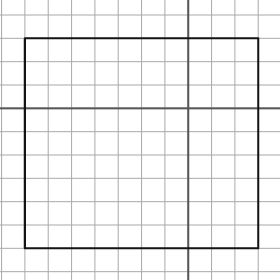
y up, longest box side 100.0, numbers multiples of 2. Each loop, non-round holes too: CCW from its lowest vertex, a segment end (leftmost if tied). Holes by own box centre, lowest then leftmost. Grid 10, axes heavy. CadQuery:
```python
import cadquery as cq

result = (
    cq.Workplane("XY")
    .moveTo(-70.0, -60.0)
    .lineTo(30.0, -60.0)
    .lineTo(30.0, 30.0)
    .lineTo(-70.0, 30.0)
    .close()
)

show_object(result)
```